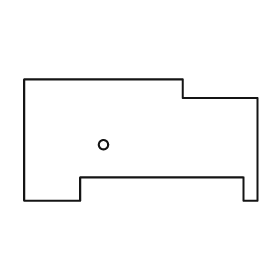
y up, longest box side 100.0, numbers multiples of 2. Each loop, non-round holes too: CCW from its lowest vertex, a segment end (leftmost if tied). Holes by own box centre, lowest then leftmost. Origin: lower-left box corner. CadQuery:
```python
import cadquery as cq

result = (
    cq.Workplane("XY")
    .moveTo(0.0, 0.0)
    .lineTo(24.0, 0.0)
    .lineTo(24.0, 10.0)
    .lineTo(94.0, 10.0)
    .lineTo(94.0, 0.0)
    .lineTo(100.0, 0.0)
    .lineTo(100.0, 44.0)
    .lineTo(68.0, 44.0)
    .lineTo(68.0, 52.0)
    .lineTo(0.0, 52.0)
    .close()
    .moveTo(34.0, 24.0)
    .circle(2.0)
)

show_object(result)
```